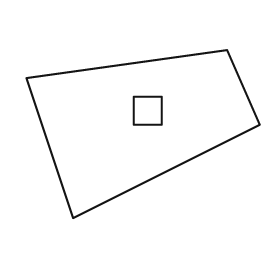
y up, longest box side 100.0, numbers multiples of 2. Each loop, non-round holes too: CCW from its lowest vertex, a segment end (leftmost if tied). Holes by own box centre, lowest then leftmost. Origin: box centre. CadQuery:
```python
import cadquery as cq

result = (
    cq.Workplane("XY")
    .moveTo(-30.0, -36.0)
    .lineTo(50.0, 4.0)
    .lineTo(36.0, 36.0)
    .lineTo(-50.0, 24.0)
    .close()
    .moveTo(-4.0, 4.0)
    .lineTo(8.0, 4.0)
    .lineTo(8.0, 16.0)
    .lineTo(-4.0, 16.0)
    .close()
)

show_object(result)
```